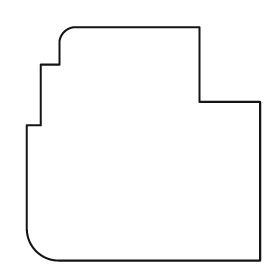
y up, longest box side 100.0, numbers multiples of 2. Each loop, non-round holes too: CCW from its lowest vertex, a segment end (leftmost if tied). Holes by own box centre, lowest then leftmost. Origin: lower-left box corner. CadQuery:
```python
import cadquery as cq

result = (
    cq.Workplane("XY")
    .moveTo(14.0, 0.0)
    .lineTo(100.0, 0.0)
    .lineTo(100.0, 68.0)
    .lineTo(74.0, 68.0)
    .lineTo(74.0, 100.0)
    .lineTo(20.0, 100.0)
    .threePointArc((16.0, 98.0), (14.0, 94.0))
    .lineTo(14.0, 84.0)
    .lineTo(6.0, 84.0)
    .lineTo(6.0, 58.0)
    .lineTo(0.0, 58.0)
    .lineTo(0.0, 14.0)
    .threePointArc((4.0, 4.0), (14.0, 0.0))
    .close()
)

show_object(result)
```